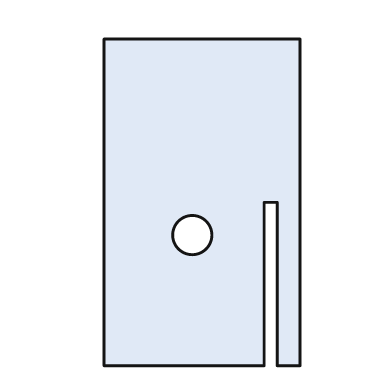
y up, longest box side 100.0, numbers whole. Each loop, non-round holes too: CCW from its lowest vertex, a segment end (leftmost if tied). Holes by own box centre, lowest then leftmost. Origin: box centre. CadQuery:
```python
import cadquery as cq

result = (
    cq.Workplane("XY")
    .moveTo(-30.0, -50.0)
    .lineTo(19.0, -50.0)
    .lineTo(19.0, 0.0)
    .lineTo(23.0, 0.0)
    .lineTo(23.0, -50.0)
    .lineTo(30.0, -50.0)
    .lineTo(30.0, 50.0)
    .lineTo(-30.0, 50.0)
    .close()
    .moveTo(-3.0, -10.0)
    .circle(6.0)
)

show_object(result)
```